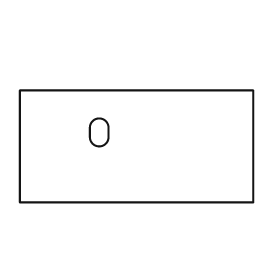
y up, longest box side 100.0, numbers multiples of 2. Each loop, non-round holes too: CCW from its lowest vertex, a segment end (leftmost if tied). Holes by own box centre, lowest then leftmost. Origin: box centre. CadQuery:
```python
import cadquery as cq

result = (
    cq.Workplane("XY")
    .moveTo(-50.0, -24.0)
    .lineTo(50.0, -24.0)
    .lineTo(50.0, 24.0)
    .lineTo(-50.0, 24.0)
    .close()
    .moveTo(-20.0, 4.0)
    .threePointArc((-16.0, 0.0), (-12.0, 4.0))
    .lineTo(-12.0, 8.0)
    .threePointArc((-16.0, 12.0), (-20.0, 8.0))
    .close()
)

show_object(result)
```